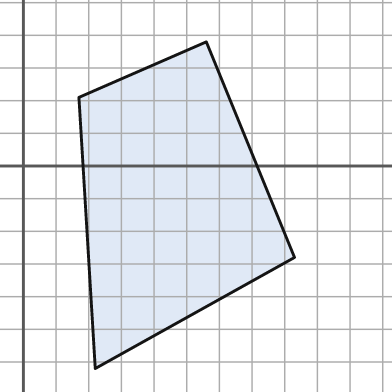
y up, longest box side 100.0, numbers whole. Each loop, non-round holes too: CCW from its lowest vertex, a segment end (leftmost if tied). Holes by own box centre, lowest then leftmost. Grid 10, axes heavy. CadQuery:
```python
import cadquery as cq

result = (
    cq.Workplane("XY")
    .moveTo(22.0, -62.0)
    .lineTo(83.0, -28.0)
    .lineTo(56.0, 38.0)
    .lineTo(17.0, 21.0)
    .close()
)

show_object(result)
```